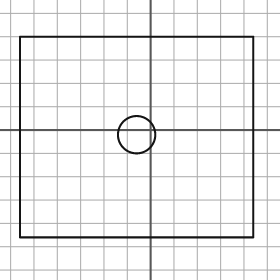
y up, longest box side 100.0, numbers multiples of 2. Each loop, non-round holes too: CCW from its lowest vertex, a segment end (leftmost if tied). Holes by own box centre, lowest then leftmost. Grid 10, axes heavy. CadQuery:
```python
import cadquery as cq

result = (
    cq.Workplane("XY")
    .moveTo(-56.0, -46.0)
    .lineTo(44.0, -46.0)
    .lineTo(44.0, 40.0)
    .lineTo(-56.0, 40.0)
    .close()
    .moveTo(-6.0, -2.0)
    .circle(8.0)
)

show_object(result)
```